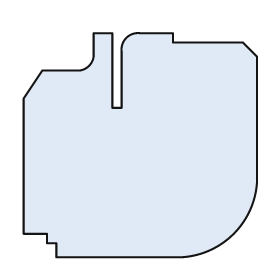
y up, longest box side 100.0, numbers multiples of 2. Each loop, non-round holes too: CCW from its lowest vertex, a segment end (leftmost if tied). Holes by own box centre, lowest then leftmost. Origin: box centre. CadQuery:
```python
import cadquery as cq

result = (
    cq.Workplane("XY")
    .moveTo(-36.0, -48.0)
    .lineTo(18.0, -48.0)
    .threePointArc((40.0, -38.0), (50.0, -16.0))
    .lineTo(50.0, 38.0)
    .lineTo(44.0, 44.0)
    .lineTo(14.0, 44.0)
    .lineTo(14.0, 48.0)
    .lineTo(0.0, 48.0)
    .threePointArc((-6.0, 46.0), (-8.0, 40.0))
    .lineTo(-8.0, 16.0)
    .lineTo(-12.0, 16.0)
    .lineTo(-12.0, 48.0)
    .lineTo(-20.0, 48.0)
    .lineTo(-20.0, 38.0)
    .threePointArc((-22.0, 34.0), (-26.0, 32.0))
    .lineTo(-42.0, 32.0)
    .lineTo(-50.0, 20.0)
    .lineTo(-50.0, -38.0)
    .lineTo(-40.0, -38.0)
    .lineTo(-40.0, -42.0)
    .lineTo(-36.0, -42.0)
    .close()
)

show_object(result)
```